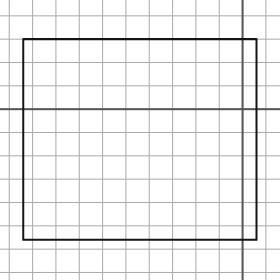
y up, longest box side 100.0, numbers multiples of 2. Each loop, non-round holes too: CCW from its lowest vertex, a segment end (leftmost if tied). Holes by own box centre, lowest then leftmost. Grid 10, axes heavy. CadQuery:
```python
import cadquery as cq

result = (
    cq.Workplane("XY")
    .moveTo(-94.0, -56.0)
    .lineTo(6.0, -56.0)
    .lineTo(6.0, 30.0)
    .lineTo(-94.0, 30.0)
    .close()
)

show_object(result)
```